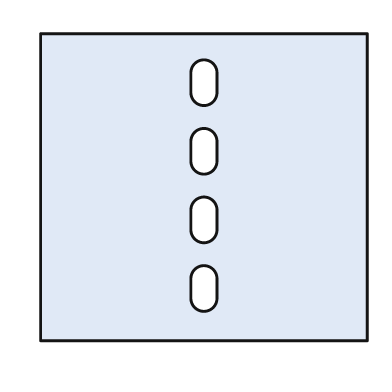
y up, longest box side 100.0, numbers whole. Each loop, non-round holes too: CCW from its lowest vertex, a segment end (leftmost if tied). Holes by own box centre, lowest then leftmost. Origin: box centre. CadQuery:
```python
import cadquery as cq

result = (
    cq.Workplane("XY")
    .moveTo(-50.0, -47.0)
    .lineTo(50.0, -47.0)
    .lineTo(50.0, 47.0)
    .lineTo(-50.0, 47.0)
    .close()
    .moveTo(-4.0, -34.0)
    .threePointArc((0.0, -38.0), (4.0, -34.0))
    .lineTo(4.0, -28.0)
    .threePointArc((0.0, -24.0), (-4.0, -28.0))
    .close()
    .moveTo(-4.0, -13.0)
    .threePointArc((0.0, -17.0), (4.0, -13.0))
    .lineTo(4.0, -7.0)
    .threePointArc((0.0, -3.0), (-4.0, -7.0))
    .close()
    .moveTo(-4.0, 8.0)
    .threePointArc((0.0, 4.0), (4.0, 8.0))
    .lineTo(4.0, 14.0)
    .threePointArc((0.0, 18.0), (-4.0, 14.0))
    .close()
    .moveTo(-4.0, 29.0)
    .threePointArc((0.0, 25.0), (4.0, 29.0))
    .lineTo(4.0, 35.0)
    .threePointArc((0.0, 39.0), (-4.0, 35.0))
    .close()
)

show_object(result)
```